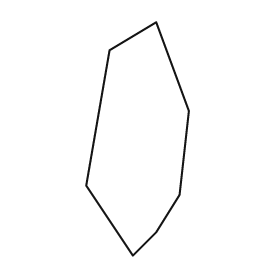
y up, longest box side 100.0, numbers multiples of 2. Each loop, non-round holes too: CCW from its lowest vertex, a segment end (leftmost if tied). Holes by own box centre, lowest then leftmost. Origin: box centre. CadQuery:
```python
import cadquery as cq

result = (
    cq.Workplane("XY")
    .moveTo(-2.0, -50.0)
    .lineTo(8.0, -40.0)
    .lineTo(18.0, -24.0)
    .lineTo(22.0, 12.0)
    .lineTo(8.0, 50.0)
    .lineTo(-12.0, 38.0)
    .lineTo(-22.0, -20.0)
    .close()
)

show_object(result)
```